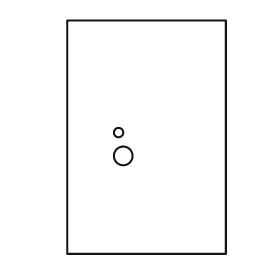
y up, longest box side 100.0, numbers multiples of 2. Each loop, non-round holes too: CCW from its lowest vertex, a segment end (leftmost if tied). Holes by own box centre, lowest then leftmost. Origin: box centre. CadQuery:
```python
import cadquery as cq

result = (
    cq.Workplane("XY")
    .moveTo(-34.0, -50.0)
    .lineTo(34.0, -50.0)
    .lineTo(34.0, 50.0)
    .lineTo(-34.0, 50.0)
    .close()
    .moveTo(-10.0, -8.0)
    .circle(4.0)
    .moveTo(-12.0, 2.0)
    .circle(2.0)
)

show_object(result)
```